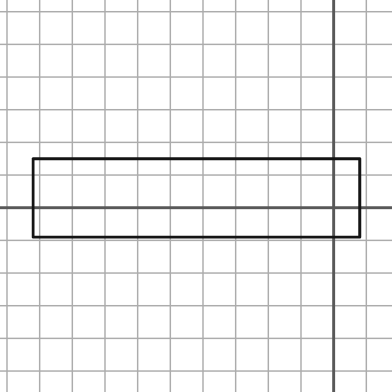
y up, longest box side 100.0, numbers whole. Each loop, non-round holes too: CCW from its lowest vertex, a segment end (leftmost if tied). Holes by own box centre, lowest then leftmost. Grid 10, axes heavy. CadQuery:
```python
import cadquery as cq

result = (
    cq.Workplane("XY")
    .moveTo(-92.0, -9.0)
    .lineTo(8.0, -9.0)
    .lineTo(8.0, 15.0)
    .lineTo(-92.0, 15.0)
    .close()
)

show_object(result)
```